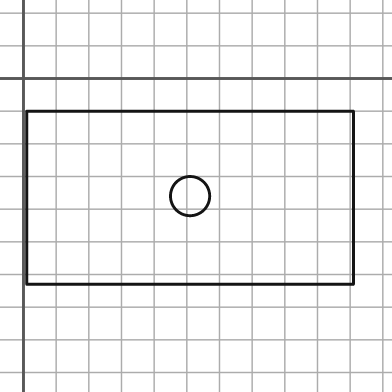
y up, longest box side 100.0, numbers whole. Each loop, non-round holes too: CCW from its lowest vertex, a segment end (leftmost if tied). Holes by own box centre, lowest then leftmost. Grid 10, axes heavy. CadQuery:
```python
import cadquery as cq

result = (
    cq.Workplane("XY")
    .moveTo(1.0, -63.0)
    .lineTo(101.0, -63.0)
    .lineTo(101.0, -10.0)
    .lineTo(1.0, -10.0)
    .close()
    .moveTo(51.0, -36.0)
    .circle(6.0)
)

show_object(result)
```